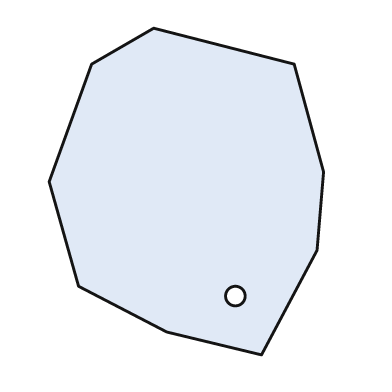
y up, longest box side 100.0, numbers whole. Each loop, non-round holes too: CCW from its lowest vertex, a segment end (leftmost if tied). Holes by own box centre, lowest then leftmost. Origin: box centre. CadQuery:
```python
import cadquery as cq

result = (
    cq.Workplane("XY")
    .moveTo(23.0, -50.0)
    .lineTo(40.0, -18.0)
    .lineTo(42.0, 6.0)
    .lineTo(33.0, 39.0)
    .lineTo(-10.0, 50.0)
    .lineTo(-29.0, 39.0)
    .lineTo(-42.0, 3.0)
    .lineTo(-33.0, -29.0)
    .lineTo(-6.0, -43.0)
    .close()
    .moveTo(15.0, -32.0)
    .circle(3.0)
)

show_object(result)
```